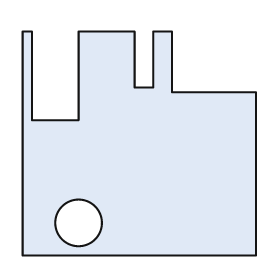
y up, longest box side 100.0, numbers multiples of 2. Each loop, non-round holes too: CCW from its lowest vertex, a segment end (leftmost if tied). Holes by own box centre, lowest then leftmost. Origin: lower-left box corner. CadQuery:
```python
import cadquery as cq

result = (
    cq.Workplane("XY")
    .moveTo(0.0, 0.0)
    .lineTo(100.0, 0.0)
    .lineTo(100.0, 70.0)
    .lineTo(64.0, 70.0)
    .lineTo(64.0, 96.0)
    .lineTo(56.0, 96.0)
    .lineTo(56.0, 72.0)
    .lineTo(48.0, 72.0)
    .lineTo(48.0, 96.0)
    .lineTo(24.0, 96.0)
    .lineTo(24.0, 58.0)
    .lineTo(4.0, 58.0)
    .lineTo(4.0, 96.0)
    .lineTo(0.0, 96.0)
    .close()
    .moveTo(24.0, 14.0)
    .circle(10.0)
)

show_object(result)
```